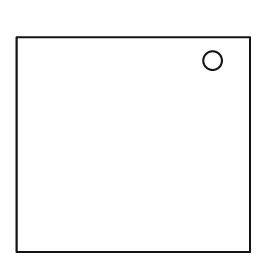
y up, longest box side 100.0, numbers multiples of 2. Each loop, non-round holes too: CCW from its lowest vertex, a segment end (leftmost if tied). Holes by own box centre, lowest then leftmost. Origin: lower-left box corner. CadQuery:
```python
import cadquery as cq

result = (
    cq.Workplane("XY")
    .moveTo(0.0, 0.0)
    .lineTo(100.0, 0.0)
    .lineTo(100.0, 92.0)
    .lineTo(0.0, 92.0)
    .close()
    .moveTo(84.0, 82.0)
    .circle(4.0)
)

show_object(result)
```